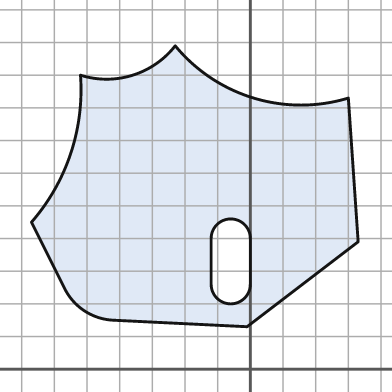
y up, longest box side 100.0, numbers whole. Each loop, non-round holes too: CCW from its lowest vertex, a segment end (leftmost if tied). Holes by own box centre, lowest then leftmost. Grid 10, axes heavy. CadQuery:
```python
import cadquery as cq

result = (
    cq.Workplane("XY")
    .moveTo(-1.0, 13.0)
    .lineTo(33.0, 39.0)
    .lineTo(30.0, 83.0)
    .threePointArc((1.0, 83.0), (-23.0, 99.0))
    .threePointArc((-36.0, 90.0), (-52.0, 90.0))
    .threePointArc((-55.0, 66.0), (-67.0, 45.0))
    .lineTo(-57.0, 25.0)
    .threePointArc((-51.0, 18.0), (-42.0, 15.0))
    .close()
    .moveTo(-12.0, 26.0)
    .threePointArc((-6.0, 20.0), (0.0, 26.0))
    .lineTo(0.0, 40.0)
    .threePointArc((-6.0, 46.0), (-12.0, 40.0))
    .close()
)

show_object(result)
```